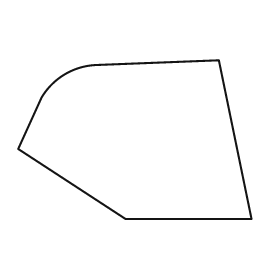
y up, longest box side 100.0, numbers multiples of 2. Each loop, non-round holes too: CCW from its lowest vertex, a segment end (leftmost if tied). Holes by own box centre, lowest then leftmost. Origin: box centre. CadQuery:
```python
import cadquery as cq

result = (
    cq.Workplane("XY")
    .moveTo(-4.0, -34.0)
    .lineTo(50.0, -34.0)
    .lineTo(36.0, 34.0)
    .lineTo(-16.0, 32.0)
    .threePointArc((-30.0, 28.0), (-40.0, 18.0))
    .lineTo(-50.0, -4.0)
    .close()
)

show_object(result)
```